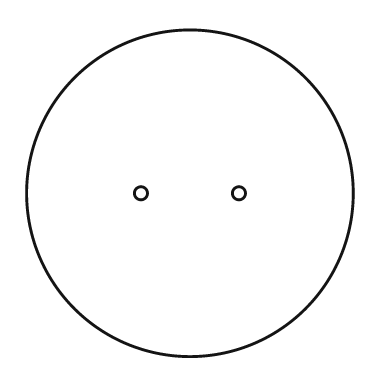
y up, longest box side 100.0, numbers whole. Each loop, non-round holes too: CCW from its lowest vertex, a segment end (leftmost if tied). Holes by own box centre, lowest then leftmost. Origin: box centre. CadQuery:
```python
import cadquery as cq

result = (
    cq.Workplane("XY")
    .moveTo(0.0, 0.0)
    .circle(50.0)
    .moveTo(-15.0, 0.0)
    .circle(2.0)
    .moveTo(15.0, 0.0)
    .circle(2.0)
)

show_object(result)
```